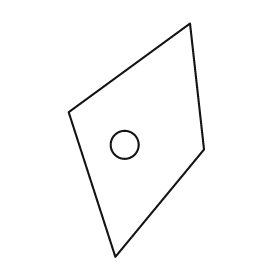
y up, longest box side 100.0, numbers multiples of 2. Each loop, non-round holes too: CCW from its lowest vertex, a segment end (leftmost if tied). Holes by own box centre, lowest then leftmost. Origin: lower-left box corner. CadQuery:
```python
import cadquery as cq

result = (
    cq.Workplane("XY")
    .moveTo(20.0, 0.0)
    .lineTo(58.0, 46.0)
    .lineTo(52.0, 100.0)
    .lineTo(0.0, 62.0)
    .close()
    .moveTo(24.0, 48.0)
    .circle(6.0)
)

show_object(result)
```